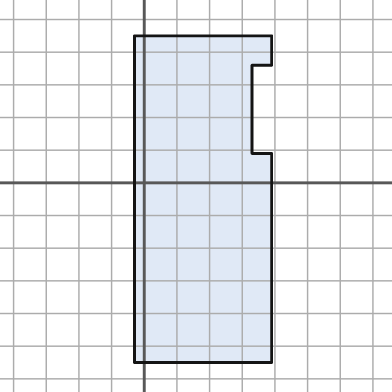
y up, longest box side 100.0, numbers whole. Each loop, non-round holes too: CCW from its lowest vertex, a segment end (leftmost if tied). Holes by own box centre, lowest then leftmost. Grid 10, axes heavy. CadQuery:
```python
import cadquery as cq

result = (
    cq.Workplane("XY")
    .moveTo(-3.0, -55.0)
    .lineTo(39.0, -55.0)
    .lineTo(39.0, 9.0)
    .lineTo(33.0, 9.0)
    .lineTo(33.0, 36.0)
    .lineTo(39.0, 36.0)
    .lineTo(39.0, 45.0)
    .lineTo(-3.0, 45.0)
    .close()
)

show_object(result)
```